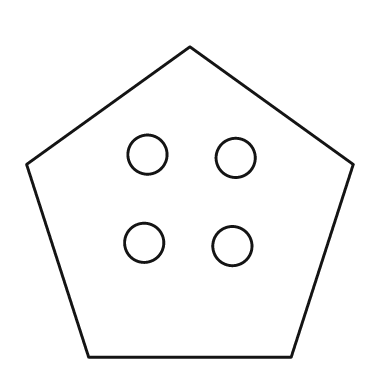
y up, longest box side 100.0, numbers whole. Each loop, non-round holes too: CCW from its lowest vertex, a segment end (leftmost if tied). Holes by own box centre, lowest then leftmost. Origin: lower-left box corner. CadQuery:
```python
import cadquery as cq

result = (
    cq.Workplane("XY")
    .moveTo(19.0, 0.0)
    .lineTo(81.0, 0.0)
    .lineTo(100.0, 59.0)
    .lineTo(50.0, 95.0)
    .lineTo(0.0, 59.0)
    .close()
    .moveTo(63.0, 34.0)
    .circle(6.0)
    .moveTo(36.0, 35.0)
    .circle(6.0)
    .moveTo(64.0, 61.0)
    .circle(6.0)
    .moveTo(37.0, 62.0)
    .circle(6.0)
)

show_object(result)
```